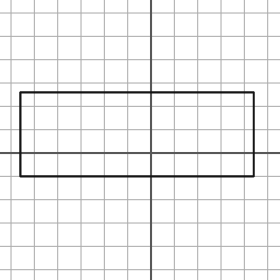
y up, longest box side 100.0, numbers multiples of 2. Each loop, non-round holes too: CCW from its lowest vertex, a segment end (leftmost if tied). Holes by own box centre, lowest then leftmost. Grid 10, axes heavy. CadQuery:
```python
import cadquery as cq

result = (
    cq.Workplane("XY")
    .moveTo(-56.0, -10.0)
    .lineTo(44.0, -10.0)
    .lineTo(44.0, 26.0)
    .lineTo(-56.0, 26.0)
    .close()
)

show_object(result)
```